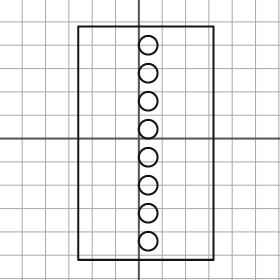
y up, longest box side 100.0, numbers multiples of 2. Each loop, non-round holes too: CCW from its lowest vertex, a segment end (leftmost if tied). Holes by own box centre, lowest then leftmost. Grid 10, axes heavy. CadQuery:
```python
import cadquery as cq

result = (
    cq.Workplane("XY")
    .moveTo(-26.0, -52.0)
    .lineTo(32.0, -52.0)
    .lineTo(32.0, 48.0)
    .lineTo(-26.0, 48.0)
    .close()
    .moveTo(4.0, -44.0)
    .circle(4.0)
    .moveTo(4.0, -32.0)
    .circle(4.0)
    .moveTo(4.0, -20.0)
    .circle(4.0)
    .moveTo(4.0, -8.0)
    .circle(4.0)
    .moveTo(4.0, 4.0)
    .circle(4.0)
    .moveTo(4.0, 16.0)
    .circle(4.0)
    .moveTo(4.0, 28.0)
    .circle(4.0)
    .moveTo(4.0, 40.0)
    .circle(4.0)
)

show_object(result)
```